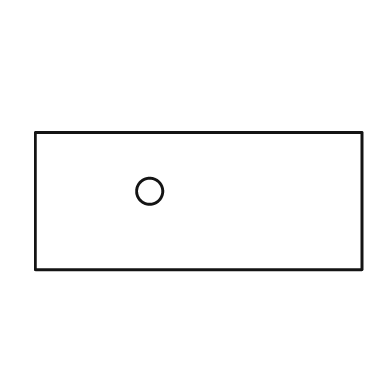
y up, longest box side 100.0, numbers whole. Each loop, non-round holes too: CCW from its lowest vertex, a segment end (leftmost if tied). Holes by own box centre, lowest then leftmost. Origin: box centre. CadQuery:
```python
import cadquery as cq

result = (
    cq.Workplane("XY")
    .moveTo(-50.0, -21.0)
    .lineTo(50.0, -21.0)
    .lineTo(50.0, 21.0)
    .lineTo(-50.0, 21.0)
    .close()
    .moveTo(-15.0, 3.0)
    .circle(4.0)
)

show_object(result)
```